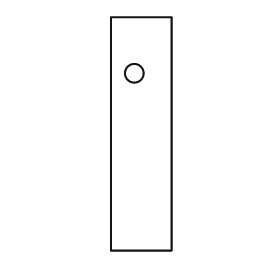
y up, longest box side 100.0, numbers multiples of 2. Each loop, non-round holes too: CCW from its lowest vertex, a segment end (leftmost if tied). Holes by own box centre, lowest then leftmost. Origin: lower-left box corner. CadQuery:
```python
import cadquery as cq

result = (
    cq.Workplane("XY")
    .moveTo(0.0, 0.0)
    .lineTo(26.0, 0.0)
    .lineTo(26.0, 100.0)
    .lineTo(0.0, 100.0)
    .close()
    .moveTo(10.0, 76.0)
    .circle(4.0)
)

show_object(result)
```